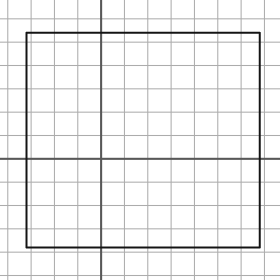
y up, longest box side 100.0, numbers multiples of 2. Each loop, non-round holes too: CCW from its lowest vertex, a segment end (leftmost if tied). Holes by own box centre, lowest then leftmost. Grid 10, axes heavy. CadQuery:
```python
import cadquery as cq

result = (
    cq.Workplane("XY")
    .moveTo(-32.0, -38.0)
    .lineTo(68.0, -38.0)
    .lineTo(68.0, 54.0)
    .lineTo(-32.0, 54.0)
    .close()
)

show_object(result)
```